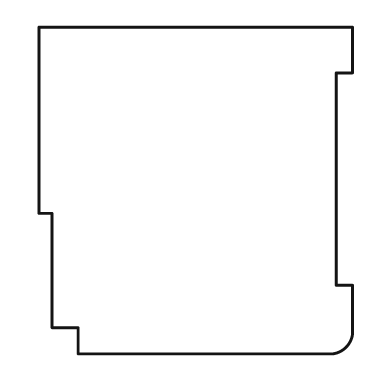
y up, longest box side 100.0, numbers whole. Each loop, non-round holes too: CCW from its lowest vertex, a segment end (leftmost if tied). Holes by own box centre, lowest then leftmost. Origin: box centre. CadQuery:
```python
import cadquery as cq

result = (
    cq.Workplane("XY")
    .moveTo(-36.0, -50.0)
    .lineTo(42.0, -50.0)
    .threePointArc((46.0, -48.0), (48.0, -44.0))
    .lineTo(48.0, -29.0)
    .lineTo(43.0, -29.0)
    .lineTo(43.0, 36.0)
    .lineTo(48.0, 36.0)
    .lineTo(48.0, 50.0)
    .lineTo(-48.0, 50.0)
    .lineTo(-48.0, -7.0)
    .lineTo(-44.0, -7.0)
    .lineTo(-44.0, -42.0)
    .lineTo(-36.0, -42.0)
    .close()
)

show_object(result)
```